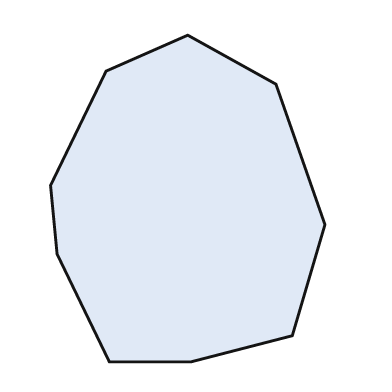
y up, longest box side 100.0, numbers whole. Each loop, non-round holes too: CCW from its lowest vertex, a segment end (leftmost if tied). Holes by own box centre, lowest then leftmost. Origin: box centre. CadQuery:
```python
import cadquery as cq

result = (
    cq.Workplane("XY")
    .moveTo(-24.0, -50.0)
    .lineTo(1.0, -50.0)
    .lineTo(32.0, -42.0)
    .lineTo(42.0, -8.0)
    .lineTo(27.0, 35.0)
    .lineTo(0.0, 50.0)
    .lineTo(-25.0, 39.0)
    .lineTo(-42.0, 4.0)
    .lineTo(-40.0, -17.0)
    .close()
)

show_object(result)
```